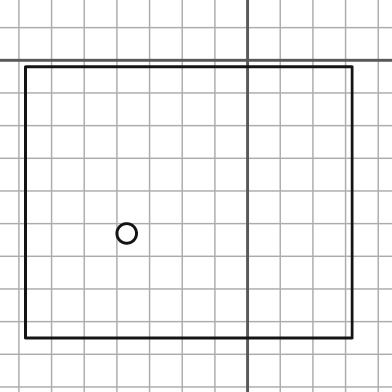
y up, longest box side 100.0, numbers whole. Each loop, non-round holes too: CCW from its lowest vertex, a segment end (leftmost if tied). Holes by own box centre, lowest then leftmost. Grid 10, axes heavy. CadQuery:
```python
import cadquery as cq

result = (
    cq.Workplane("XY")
    .moveTo(-68.0, -85.0)
    .lineTo(32.0, -85.0)
    .lineTo(32.0, -2.0)
    .lineTo(-68.0, -2.0)
    .close()
    .moveTo(-37.0, -53.0)
    .circle(3.0)
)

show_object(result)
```